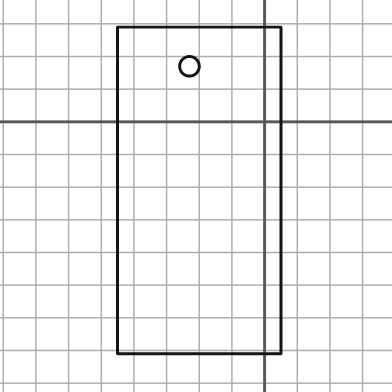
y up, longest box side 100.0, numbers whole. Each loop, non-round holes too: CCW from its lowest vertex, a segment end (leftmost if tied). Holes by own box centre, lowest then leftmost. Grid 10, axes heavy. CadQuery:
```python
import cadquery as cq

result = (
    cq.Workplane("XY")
    .moveTo(-45.0, -71.0)
    .lineTo(5.0, -71.0)
    .lineTo(5.0, 29.0)
    .lineTo(-45.0, 29.0)
    .close()
    .moveTo(-23.0, 17.0)
    .circle(3.0)
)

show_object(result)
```